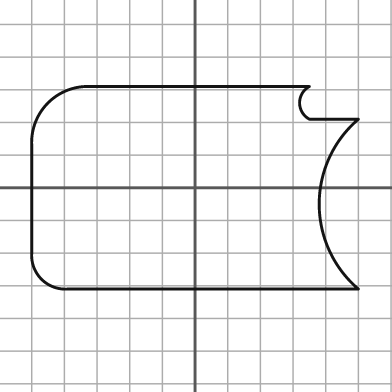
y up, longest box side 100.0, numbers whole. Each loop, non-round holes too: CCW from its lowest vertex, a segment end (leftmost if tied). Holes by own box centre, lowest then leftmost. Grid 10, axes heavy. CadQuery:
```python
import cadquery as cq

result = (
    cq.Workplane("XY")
    .moveTo(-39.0, -31.0)
    .lineTo(50.0, -31.0)
    .threePointArc((38.0, -5.0), (50.0, 21.0))
    .lineTo(35.0, 21.0)
    .threePointArc((32.0, 26.0), (35.0, 31.0))
    .lineTo(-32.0, 31.0)
    .threePointArc((-45.0, 26.0), (-50.0, 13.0))
    .lineTo(-50.0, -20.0)
    .threePointArc((-47.0, -28.0), (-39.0, -31.0))
    .close()
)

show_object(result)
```